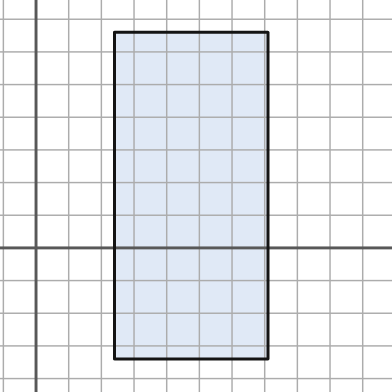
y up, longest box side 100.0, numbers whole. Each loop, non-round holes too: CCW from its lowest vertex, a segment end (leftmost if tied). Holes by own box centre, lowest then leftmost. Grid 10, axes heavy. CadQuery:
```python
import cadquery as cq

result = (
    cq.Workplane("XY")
    .moveTo(24.0, -34.0)
    .lineTo(71.0, -34.0)
    .lineTo(71.0, 66.0)
    .lineTo(24.0, 66.0)
    .close()
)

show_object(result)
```